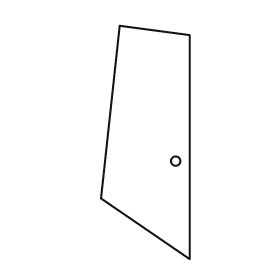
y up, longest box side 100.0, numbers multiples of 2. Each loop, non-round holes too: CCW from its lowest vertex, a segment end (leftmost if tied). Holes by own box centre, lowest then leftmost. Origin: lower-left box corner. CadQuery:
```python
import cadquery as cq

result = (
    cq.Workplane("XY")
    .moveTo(38.0, 0.0)
    .lineTo(38.0, 96.0)
    .lineTo(8.0, 100.0)
    .lineTo(0.0, 26.0)
    .close()
    .moveTo(32.0, 42.0)
    .circle(2.0)
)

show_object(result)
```